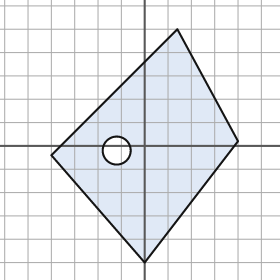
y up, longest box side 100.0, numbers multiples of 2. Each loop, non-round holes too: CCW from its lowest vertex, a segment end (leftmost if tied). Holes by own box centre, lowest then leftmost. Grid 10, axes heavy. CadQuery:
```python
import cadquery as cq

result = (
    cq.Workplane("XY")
    .moveTo(0.0, -50.0)
    .lineTo(40.0, 2.0)
    .lineTo(14.0, 50.0)
    .lineTo(-40.0, -4.0)
    .close()
    .moveTo(-12.0, -2.0)
    .circle(6.0)
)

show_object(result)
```